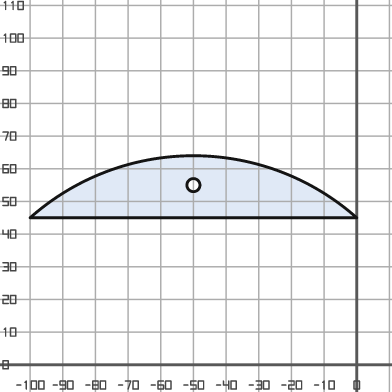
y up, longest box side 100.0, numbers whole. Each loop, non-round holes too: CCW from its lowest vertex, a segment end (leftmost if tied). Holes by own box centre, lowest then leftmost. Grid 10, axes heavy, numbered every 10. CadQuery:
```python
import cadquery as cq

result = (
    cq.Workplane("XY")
    .moveTo(-100.0, 45.0)
    .lineTo(0.0, 45.0)
    .threePointArc((-50.0, 64.0), (-100.0, 45.0))
    .close()
    .moveTo(-50.0, 55.0)
    .circle(2.0)
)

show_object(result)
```